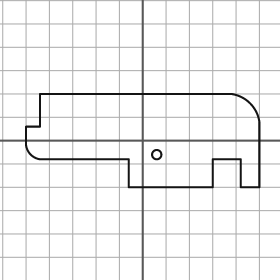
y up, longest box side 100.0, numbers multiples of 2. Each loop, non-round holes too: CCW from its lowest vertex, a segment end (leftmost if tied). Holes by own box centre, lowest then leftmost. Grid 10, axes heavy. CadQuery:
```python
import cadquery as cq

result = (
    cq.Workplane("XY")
    .moveTo(-6.0, -20.0)
    .lineTo(30.0, -20.0)
    .lineTo(30.0, -8.0)
    .lineTo(42.0, -8.0)
    .lineTo(42.0, -20.0)
    .lineTo(50.0, -20.0)
    .lineTo(50.0, 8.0)
    .threePointArc((46.0, 16.0), (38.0, 20.0))
    .lineTo(-44.0, 20.0)
    .lineTo(-44.0, 6.0)
    .lineTo(-50.0, 6.0)
    .lineTo(-50.0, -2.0)
    .threePointArc((-48.0, -6.0), (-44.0, -8.0))
    .lineTo(-6.0, -8.0)
    .close()
    .moveTo(6.0, -6.0)
    .circle(2.0)
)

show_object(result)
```